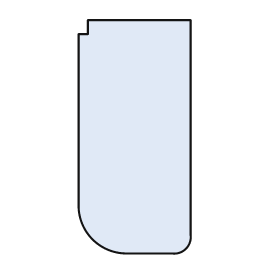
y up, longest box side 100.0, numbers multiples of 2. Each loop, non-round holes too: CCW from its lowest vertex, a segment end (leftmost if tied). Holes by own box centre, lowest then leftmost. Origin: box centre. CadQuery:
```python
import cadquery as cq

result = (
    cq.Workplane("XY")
    .moveTo(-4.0, -50.0)
    .lineTo(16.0, -50.0)
    .threePointArc((22.0, -48.0), (24.0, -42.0))
    .lineTo(24.0, 50.0)
    .lineTo(-20.0, 50.0)
    .lineTo(-20.0, 44.0)
    .lineTo(-24.0, 44.0)
    .lineTo(-24.0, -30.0)
    .threePointArc((-18.0, -44.0), (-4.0, -50.0))
    .close()
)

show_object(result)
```